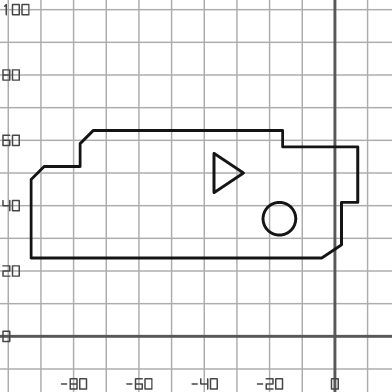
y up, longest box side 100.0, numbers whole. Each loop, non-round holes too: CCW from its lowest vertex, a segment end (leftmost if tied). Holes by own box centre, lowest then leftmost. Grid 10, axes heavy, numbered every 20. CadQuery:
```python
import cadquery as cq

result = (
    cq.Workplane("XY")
    .moveTo(-93.0, 24.0)
    .lineTo(-4.0, 24.0)
    .lineTo(2.0, 28.0)
    .lineTo(2.0, 41.0)
    .lineTo(7.0, 41.0)
    .lineTo(7.0, 58.0)
    .lineTo(-16.0, 58.0)
    .lineTo(-16.0, 63.0)
    .lineTo(-74.0, 63.0)
    .lineTo(-78.0, 59.0)
    .lineTo(-78.0, 52.0)
    .lineTo(-89.0, 52.0)
    .lineTo(-93.0, 48.0)
    .close()
    .moveTo(-17.0, 36.0)
    .circle(5.0)
    .moveTo(-37.0, 44.0)
    .lineTo(-28.0, 50.0)
    .lineTo(-37.0, 56.0)
    .close()
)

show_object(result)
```